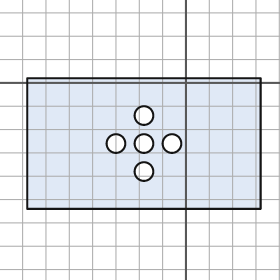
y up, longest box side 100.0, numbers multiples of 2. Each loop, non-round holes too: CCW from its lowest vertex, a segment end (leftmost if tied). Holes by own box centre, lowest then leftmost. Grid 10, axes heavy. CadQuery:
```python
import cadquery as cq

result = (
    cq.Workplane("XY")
    .moveTo(-68.0, -54.0)
    .lineTo(32.0, -54.0)
    .lineTo(32.0, 2.0)
    .lineTo(-68.0, 2.0)
    .close()
    .moveTo(-18.0, -38.0)
    .circle(4.0)
    .moveTo(-30.0, -26.0)
    .circle(4.0)
    .moveTo(-18.0, -26.0)
    .circle(4.0)
    .moveTo(-6.0, -26.0)
    .circle(4.0)
    .moveTo(-18.0, -14.0)
    .circle(4.0)
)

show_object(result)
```